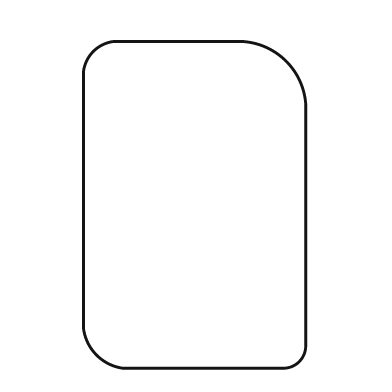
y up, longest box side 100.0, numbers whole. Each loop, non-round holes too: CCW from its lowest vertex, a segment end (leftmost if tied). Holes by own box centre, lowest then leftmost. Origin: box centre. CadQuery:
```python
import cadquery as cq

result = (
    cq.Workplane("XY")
    .moveTo(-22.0, -50.0)
    .lineTo(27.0, -50.0)
    .threePointArc((32.0, -48.0), (34.0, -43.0))
    .lineTo(34.0, 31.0)
    .threePointArc((28.0, 44.0), (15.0, 50.0))
    .lineTo(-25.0, 50.0)
    .threePointArc((-31.0, 47.0), (-34.0, 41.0))
    .lineTo(-34.0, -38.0)
    .threePointArc((-30.0, -46.0), (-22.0, -50.0))
    .close()
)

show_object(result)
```